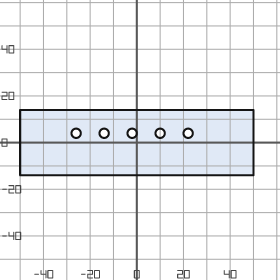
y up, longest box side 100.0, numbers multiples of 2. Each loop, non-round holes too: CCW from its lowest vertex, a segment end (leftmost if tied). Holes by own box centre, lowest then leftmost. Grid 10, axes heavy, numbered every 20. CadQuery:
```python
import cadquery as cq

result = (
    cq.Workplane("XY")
    .moveTo(-50.0, -14.0)
    .lineTo(50.0, -14.0)
    .lineTo(50.0, 14.0)
    .lineTo(-50.0, 14.0)
    .close()
    .moveTo(-26.0, 4.0)
    .circle(2.0)
    .moveTo(-14.0, 4.0)
    .circle(2.0)
    .moveTo(-2.0, 4.0)
    .circle(2.0)
    .moveTo(10.0, 4.0)
    .circle(2.0)
    .moveTo(22.0, 4.0)
    .circle(2.0)
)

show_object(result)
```